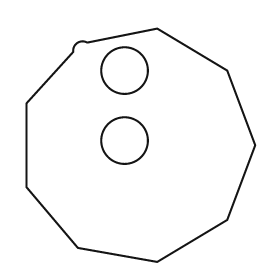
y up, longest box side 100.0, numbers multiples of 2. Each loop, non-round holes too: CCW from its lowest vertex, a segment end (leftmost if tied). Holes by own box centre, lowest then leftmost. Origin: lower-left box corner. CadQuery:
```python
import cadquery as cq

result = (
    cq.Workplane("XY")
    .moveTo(56.0, 0.0)
    .lineTo(86.0, 18.0)
    .lineTo(98.0, 50.0)
    .lineTo(86.0, 82.0)
    .lineTo(56.0, 100.0)
    .lineTo(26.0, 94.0)
    .threePointArc((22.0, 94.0), (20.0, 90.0))
    .lineTo(0.0, 68.0)
    .lineTo(0.0, 32.0)
    .lineTo(22.0, 6.0)
    .close()
    .moveTo(42.0, 52.0)
    .circle(10.0)
    .moveTo(42.0, 82.0)
    .circle(10.0)
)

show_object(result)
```